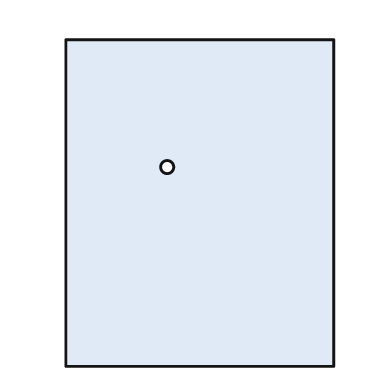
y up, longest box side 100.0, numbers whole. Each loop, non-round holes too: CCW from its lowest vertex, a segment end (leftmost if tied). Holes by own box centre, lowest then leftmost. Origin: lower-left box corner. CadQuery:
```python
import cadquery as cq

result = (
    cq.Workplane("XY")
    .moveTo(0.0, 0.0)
    .lineTo(82.0, 0.0)
    .lineTo(82.0, 100.0)
    .lineTo(0.0, 100.0)
    .close()
    .moveTo(31.0, 61.0)
    .circle(2.0)
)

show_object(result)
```